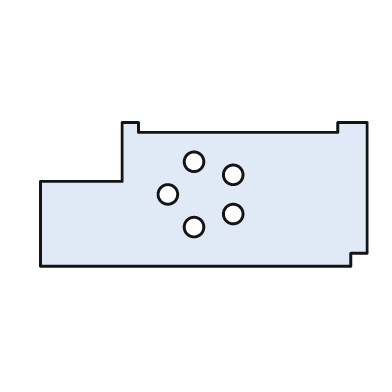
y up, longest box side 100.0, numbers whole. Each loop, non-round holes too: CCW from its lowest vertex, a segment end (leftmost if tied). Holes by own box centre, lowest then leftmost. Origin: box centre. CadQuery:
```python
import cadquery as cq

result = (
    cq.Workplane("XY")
    .moveTo(-50.0, -22.0)
    .lineTo(45.0, -22.0)
    .lineTo(45.0, -18.0)
    .lineTo(50.0, -18.0)
    .lineTo(50.0, 22.0)
    .lineTo(41.0, 22.0)
    .lineTo(41.0, 19.0)
    .lineTo(-20.0, 19.0)
    .lineTo(-20.0, 22.0)
    .lineTo(-25.0, 22.0)
    .lineTo(-25.0, 4.0)
    .lineTo(-50.0, 4.0)
    .close()
    .moveTo(-3.0, -10.0)
    .circle(3.0)
    .moveTo(9.0, -6.0)
    .circle(3.0)
    .moveTo(-11.0, 0.0)
    .circle(3.0)
    .moveTo(9.0, 6.0)
    .circle(3.0)
    .moveTo(-3.0, 10.0)
    .circle(3.0)
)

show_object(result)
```